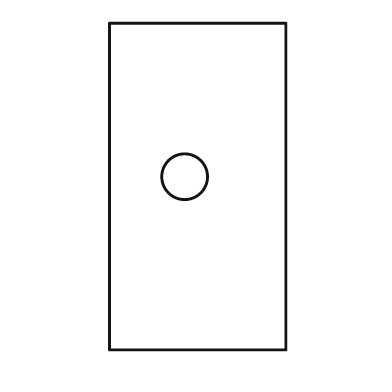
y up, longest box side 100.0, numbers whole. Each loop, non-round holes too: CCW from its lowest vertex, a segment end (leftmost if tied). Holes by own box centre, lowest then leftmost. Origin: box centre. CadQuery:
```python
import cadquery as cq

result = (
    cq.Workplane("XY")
    .moveTo(-27.0, -50.0)
    .lineTo(27.0, -50.0)
    .lineTo(27.0, 50.0)
    .lineTo(-27.0, 50.0)
    .close()
    .moveTo(-4.0, 3.0)
    .circle(7.0)
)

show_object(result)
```